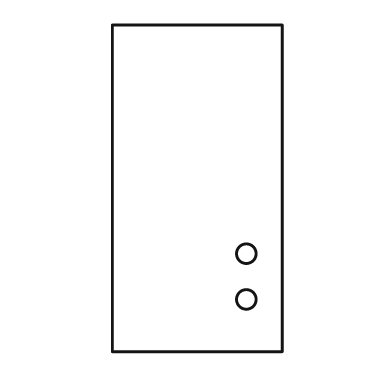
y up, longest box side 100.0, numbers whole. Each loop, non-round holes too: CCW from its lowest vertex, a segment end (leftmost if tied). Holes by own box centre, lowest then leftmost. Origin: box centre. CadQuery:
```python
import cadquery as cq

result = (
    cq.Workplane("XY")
    .moveTo(-26.0, -50.0)
    .lineTo(26.0, -50.0)
    .lineTo(26.0, 50.0)
    .lineTo(-26.0, 50.0)
    .close()
    .moveTo(15.0, -34.0)
    .circle(3.0)
    .moveTo(15.0, -20.0)
    .circle(3.0)
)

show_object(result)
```